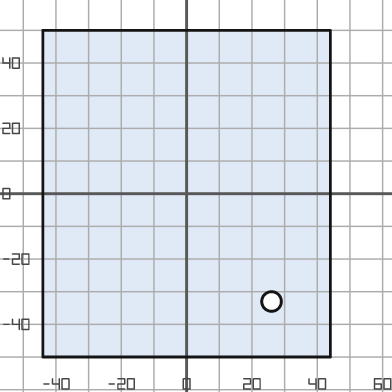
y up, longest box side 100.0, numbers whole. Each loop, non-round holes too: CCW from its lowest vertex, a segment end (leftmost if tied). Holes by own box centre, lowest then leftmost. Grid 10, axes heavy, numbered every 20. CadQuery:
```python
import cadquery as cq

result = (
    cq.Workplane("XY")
    .moveTo(-44.0, -50.0)
    .lineTo(44.0, -50.0)
    .lineTo(44.0, 50.0)
    .lineTo(-44.0, 50.0)
    .close()
    .moveTo(26.0, -33.0)
    .circle(3.0)
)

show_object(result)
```